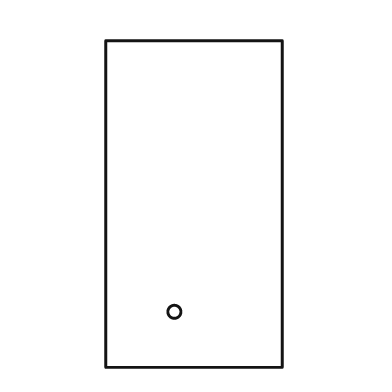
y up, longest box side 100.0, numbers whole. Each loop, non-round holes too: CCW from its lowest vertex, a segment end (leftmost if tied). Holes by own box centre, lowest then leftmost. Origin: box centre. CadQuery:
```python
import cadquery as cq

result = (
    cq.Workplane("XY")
    .moveTo(-27.0, -50.0)
    .lineTo(27.0, -50.0)
    .lineTo(27.0, 50.0)
    .lineTo(-27.0, 50.0)
    .close()
    .moveTo(-6.0, -33.0)
    .circle(2.0)
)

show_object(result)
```